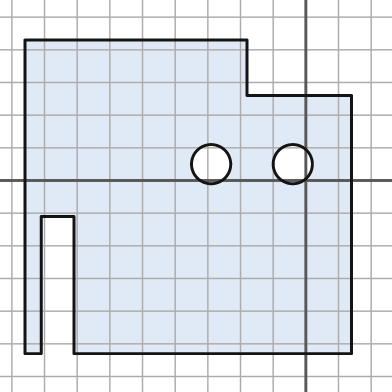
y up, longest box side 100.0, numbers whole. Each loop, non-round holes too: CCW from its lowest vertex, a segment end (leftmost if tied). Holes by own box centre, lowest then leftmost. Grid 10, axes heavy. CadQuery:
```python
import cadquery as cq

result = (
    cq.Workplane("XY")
    .moveTo(-86.0, -53.0)
    .lineTo(-81.0, -53.0)
    .lineTo(-81.0, -11.0)
    .lineTo(-71.0, -11.0)
    .lineTo(-71.0, -53.0)
    .lineTo(14.0, -53.0)
    .lineTo(14.0, 26.0)
    .lineTo(-18.0, 26.0)
    .lineTo(-18.0, 43.0)
    .lineTo(-86.0, 43.0)
    .close()
    .moveTo(-29.0, 5.0)
    .circle(6.0)
    .moveTo(-4.0, 5.0)
    .circle(6.0)
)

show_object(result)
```